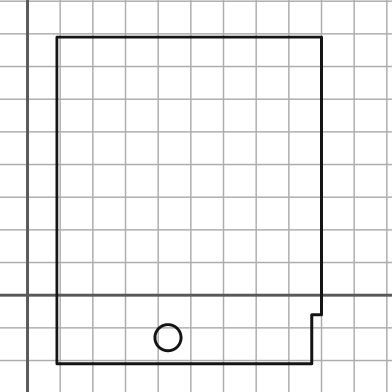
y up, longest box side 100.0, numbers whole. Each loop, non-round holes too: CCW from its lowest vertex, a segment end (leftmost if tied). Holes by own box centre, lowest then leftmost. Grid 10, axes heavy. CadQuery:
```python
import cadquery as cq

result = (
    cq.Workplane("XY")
    .moveTo(9.0, -21.0)
    .lineTo(87.0, -21.0)
    .lineTo(87.0, -6.0)
    .lineTo(90.0, -6.0)
    .lineTo(90.0, 79.0)
    .lineTo(9.0, 79.0)
    .close()
    .moveTo(43.0, -13.0)
    .circle(4.0)
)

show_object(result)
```